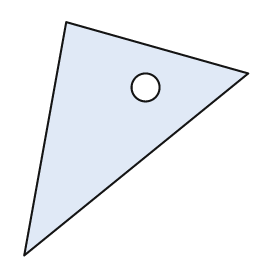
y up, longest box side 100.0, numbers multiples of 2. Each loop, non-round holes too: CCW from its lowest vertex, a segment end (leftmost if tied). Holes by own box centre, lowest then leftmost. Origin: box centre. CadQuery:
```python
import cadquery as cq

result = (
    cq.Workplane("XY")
    .moveTo(-48.0, -50.0)
    .lineTo(48.0, 28.0)
    .lineTo(-30.0, 50.0)
    .close()
    .moveTo(4.0, 22.0)
    .circle(6.0)
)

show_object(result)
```